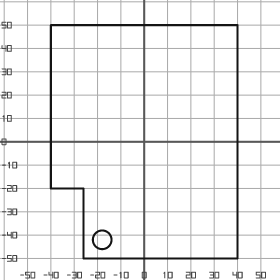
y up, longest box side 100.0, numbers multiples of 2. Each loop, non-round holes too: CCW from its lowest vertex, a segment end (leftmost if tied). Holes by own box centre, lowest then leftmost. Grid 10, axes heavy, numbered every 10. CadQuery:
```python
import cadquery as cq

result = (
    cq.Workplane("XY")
    .moveTo(-26.0, -50.0)
    .lineTo(40.0, -50.0)
    .lineTo(40.0, 50.0)
    .lineTo(-40.0, 50.0)
    .lineTo(-40.0, -20.0)
    .lineTo(-26.0, -20.0)
    .close()
    .moveTo(-18.0, -42.0)
    .circle(4.0)
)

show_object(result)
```